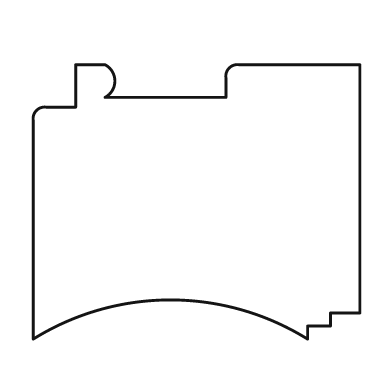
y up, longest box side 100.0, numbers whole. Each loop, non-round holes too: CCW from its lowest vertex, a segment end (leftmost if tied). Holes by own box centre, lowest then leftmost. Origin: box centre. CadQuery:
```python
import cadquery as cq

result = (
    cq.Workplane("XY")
    .moveTo(-50.0, -42.0)
    .threePointArc((-8.0, -30.0), (34.0, -42.0))
    .lineTo(34.0, -38.0)
    .lineTo(41.0, -38.0)
    .lineTo(41.0, -34.0)
    .lineTo(50.0, -34.0)
    .lineTo(50.0, 42.0)
    .lineTo(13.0, 42.0)
    .threePointArc((10.0, 41.0), (9.0, 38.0))
    .lineTo(9.0, 32.0)
    .lineTo(-28.0, 32.0)
    .threePointArc((-25.0, 37.0), (-28.0, 42.0))
    .lineTo(-37.0, 42.0)
    .lineTo(-37.0, 29.0)
    .lineTo(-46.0, 29.0)
    .threePointArc((-49.0, 28.0), (-50.0, 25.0))
    .close()
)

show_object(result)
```